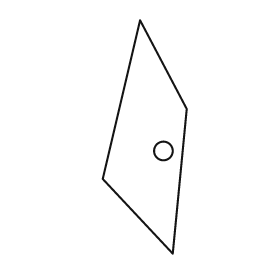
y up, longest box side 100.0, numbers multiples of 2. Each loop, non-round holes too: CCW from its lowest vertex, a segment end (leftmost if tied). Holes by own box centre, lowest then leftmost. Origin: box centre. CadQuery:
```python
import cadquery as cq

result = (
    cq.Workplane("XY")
    .moveTo(12.0, -50.0)
    .lineTo(18.0, 12.0)
    .lineTo(-2.0, 50.0)
    .lineTo(-18.0, -18.0)
    .close()
    .moveTo(8.0, -6.0)
    .circle(4.0)
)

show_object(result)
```